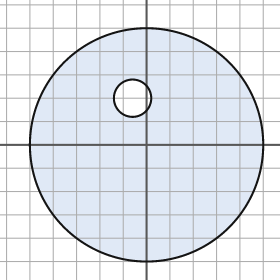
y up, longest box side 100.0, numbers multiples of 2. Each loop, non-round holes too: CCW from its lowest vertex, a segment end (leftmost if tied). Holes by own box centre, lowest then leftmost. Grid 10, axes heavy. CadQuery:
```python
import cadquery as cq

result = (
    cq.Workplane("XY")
    .moveTo(0.0, 0.0)
    .circle(50.0)
    .moveTo(-6.0, 20.0)
    .circle(8.0)
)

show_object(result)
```